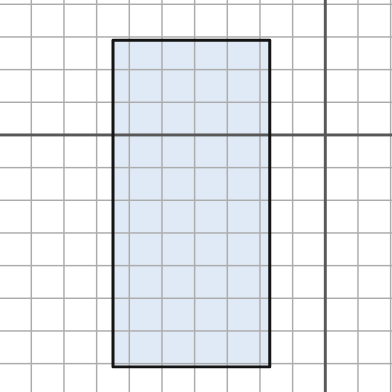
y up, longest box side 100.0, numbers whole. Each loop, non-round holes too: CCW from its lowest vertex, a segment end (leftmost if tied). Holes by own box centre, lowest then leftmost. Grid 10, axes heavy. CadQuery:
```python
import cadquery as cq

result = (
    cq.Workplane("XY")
    .moveTo(-65.0, -71.0)
    .lineTo(-17.0, -71.0)
    .lineTo(-17.0, 29.0)
    .lineTo(-65.0, 29.0)
    .close()
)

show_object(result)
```